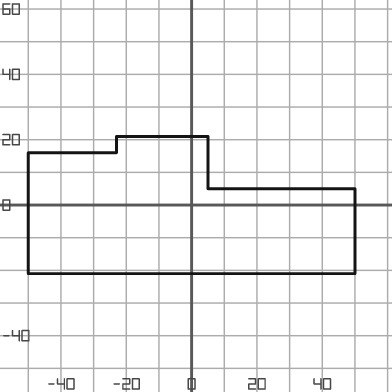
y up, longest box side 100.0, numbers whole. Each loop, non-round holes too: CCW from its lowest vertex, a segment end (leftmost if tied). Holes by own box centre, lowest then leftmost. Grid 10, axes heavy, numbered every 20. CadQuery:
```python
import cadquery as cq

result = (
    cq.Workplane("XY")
    .moveTo(-50.0, -21.0)
    .lineTo(50.0, -21.0)
    .lineTo(50.0, 5.0)
    .lineTo(5.0, 5.0)
    .lineTo(5.0, 21.0)
    .lineTo(-23.0, 21.0)
    .lineTo(-23.0, 16.0)
    .lineTo(-50.0, 16.0)
    .close()
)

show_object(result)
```